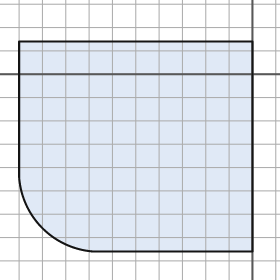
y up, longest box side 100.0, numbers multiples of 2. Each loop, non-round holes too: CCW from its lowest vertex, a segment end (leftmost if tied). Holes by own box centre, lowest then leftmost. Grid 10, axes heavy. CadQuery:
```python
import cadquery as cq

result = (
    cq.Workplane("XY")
    .moveTo(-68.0, -76.0)
    .lineTo(0.0, -76.0)
    .lineTo(0.0, 14.0)
    .lineTo(-100.0, 14.0)
    .lineTo(-100.0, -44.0)
    .threePointArc((-90.0, -66.0), (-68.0, -76.0))
    .close()
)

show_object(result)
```